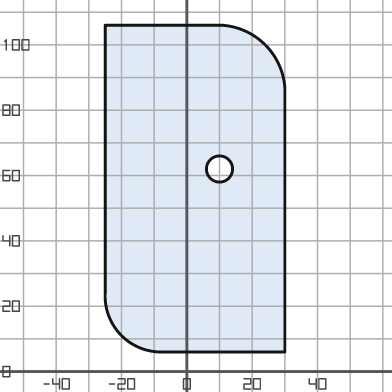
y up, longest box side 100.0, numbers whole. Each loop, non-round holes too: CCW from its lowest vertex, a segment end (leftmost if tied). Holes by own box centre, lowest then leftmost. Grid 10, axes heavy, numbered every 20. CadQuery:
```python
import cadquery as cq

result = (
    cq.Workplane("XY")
    .moveTo(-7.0, 6.0)
    .lineTo(30.0, 6.0)
    .lineTo(30.0, 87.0)
    .threePointArc((24.0, 100.0), (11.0, 106.0))
    .lineTo(-25.0, 106.0)
    .lineTo(-25.0, 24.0)
    .threePointArc((-20.0, 11.0), (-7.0, 6.0))
    .close()
    .moveTo(10.0, 62.0)
    .circle(4.0)
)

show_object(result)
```